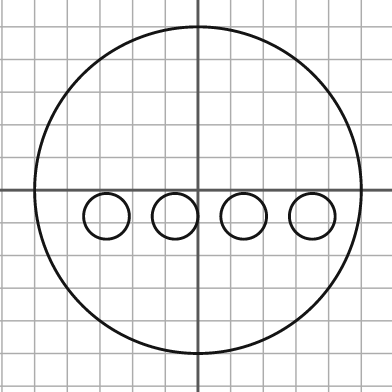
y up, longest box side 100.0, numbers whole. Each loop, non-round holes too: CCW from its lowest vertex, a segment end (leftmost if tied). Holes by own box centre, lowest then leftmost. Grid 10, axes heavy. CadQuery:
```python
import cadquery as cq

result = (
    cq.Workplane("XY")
    .moveTo(0.0, 0.0)
    .circle(50.0)
    .moveTo(-28.0, -8.0)
    .circle(7.0)
    .moveTo(-7.0, -8.0)
    .circle(7.0)
    .moveTo(14.0, -8.0)
    .circle(7.0)
    .moveTo(35.0, -8.0)
    .circle(7.0)
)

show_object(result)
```